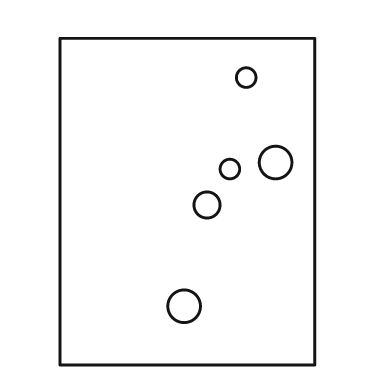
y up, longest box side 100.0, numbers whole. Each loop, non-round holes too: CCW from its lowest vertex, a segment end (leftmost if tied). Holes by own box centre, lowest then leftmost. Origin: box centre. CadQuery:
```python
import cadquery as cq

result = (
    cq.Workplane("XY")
    .moveTo(-39.0, -50.0)
    .lineTo(39.0, -50.0)
    .lineTo(39.0, 50.0)
    .lineTo(-39.0, 50.0)
    .close()
    .moveTo(-1.0, -32.0)
    .circle(5.0)
    .moveTo(6.0, -1.0)
    .circle(4.0)
    .moveTo(13.0, 10.0)
    .circle(3.0)
    .moveTo(27.0, 12.0)
    .circle(5.0)
    .moveTo(18.0, 38.0)
    .circle(3.0)
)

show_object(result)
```